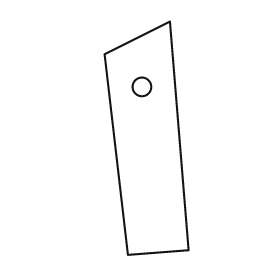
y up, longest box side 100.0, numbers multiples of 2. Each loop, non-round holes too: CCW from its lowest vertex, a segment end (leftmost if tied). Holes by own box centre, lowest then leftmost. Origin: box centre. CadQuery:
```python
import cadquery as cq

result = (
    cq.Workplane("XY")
    .moveTo(-8.0, -50.0)
    .lineTo(18.0, -48.0)
    .lineTo(10.0, 50.0)
    .lineTo(-18.0, 36.0)
    .close()
    .moveTo(-2.0, 22.0)
    .circle(4.0)
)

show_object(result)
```